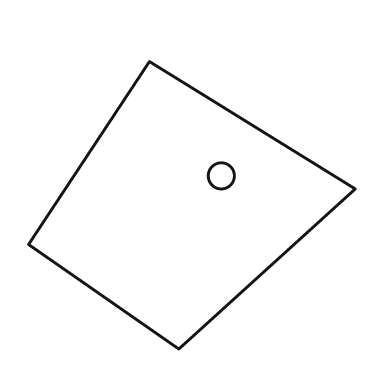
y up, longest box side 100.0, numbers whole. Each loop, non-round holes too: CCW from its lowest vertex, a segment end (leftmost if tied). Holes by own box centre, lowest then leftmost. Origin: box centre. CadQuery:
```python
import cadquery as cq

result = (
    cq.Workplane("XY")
    .moveTo(-4.0, -44.0)
    .lineTo(50.0, 5.0)
    .lineTo(-13.0, 44.0)
    .lineTo(-50.0, -12.0)
    .close()
    .moveTo(9.0, 9.0)
    .circle(4.0)
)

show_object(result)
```